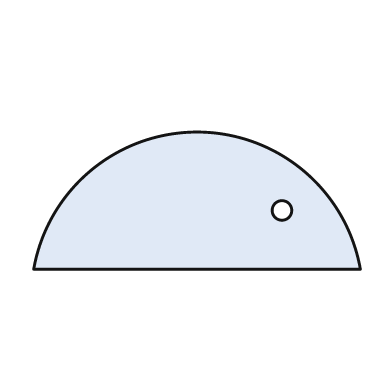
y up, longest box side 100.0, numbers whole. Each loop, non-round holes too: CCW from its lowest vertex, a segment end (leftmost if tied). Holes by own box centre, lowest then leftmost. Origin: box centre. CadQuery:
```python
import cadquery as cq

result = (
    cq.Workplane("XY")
    .moveTo(-50.0, -21.0)
    .lineTo(50.0, -21.0)
    .threePointArc((0.0, 21.0), (-50.0, -21.0))
    .close()
    .moveTo(26.0, -3.0)
    .circle(3.0)
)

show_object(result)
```